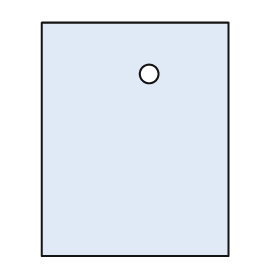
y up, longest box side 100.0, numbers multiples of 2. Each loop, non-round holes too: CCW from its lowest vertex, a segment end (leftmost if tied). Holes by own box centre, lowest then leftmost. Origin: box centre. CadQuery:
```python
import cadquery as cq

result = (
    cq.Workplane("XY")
    .moveTo(-40.0, -50.0)
    .lineTo(40.0, -50.0)
    .lineTo(40.0, 50.0)
    .lineTo(-40.0, 50.0)
    .close()
    .moveTo(6.0, 28.0)
    .circle(4.0)
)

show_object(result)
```